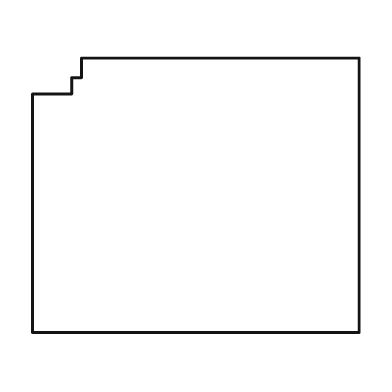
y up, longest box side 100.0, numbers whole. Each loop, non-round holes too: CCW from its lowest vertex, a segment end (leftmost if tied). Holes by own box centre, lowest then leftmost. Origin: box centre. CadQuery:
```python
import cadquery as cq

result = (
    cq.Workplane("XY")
    .moveTo(-50.0, -42.0)
    .lineTo(50.0, -42.0)
    .lineTo(50.0, 42.0)
    .lineTo(-35.0, 42.0)
    .lineTo(-35.0, 36.0)
    .lineTo(-38.0, 36.0)
    .lineTo(-38.0, 31.0)
    .lineTo(-50.0, 31.0)
    .close()
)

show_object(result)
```